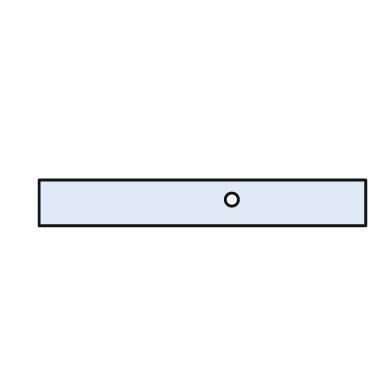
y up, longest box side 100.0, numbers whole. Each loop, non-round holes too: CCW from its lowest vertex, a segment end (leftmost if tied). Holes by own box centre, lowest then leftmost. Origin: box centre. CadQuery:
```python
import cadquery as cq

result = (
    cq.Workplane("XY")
    .moveTo(-50.0, -7.0)
    .lineTo(50.0, -7.0)
    .lineTo(50.0, 7.0)
    .lineTo(-50.0, 7.0)
    .close()
    .moveTo(9.0, 1.0)
    .circle(2.0)
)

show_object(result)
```